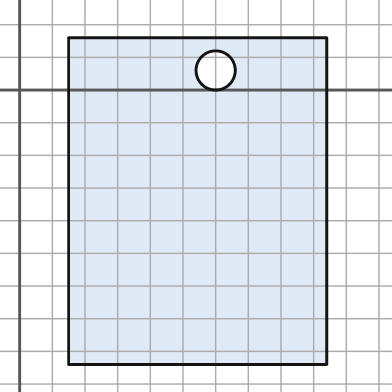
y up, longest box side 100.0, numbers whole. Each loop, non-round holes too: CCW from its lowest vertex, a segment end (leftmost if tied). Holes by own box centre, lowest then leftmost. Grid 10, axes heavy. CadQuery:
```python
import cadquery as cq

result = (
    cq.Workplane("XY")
    .moveTo(15.0, -84.0)
    .lineTo(94.0, -84.0)
    .lineTo(94.0, 16.0)
    .lineTo(15.0, 16.0)
    .close()
    .moveTo(60.0, 6.0)
    .circle(6.0)
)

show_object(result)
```